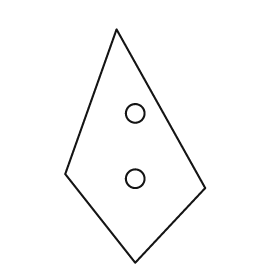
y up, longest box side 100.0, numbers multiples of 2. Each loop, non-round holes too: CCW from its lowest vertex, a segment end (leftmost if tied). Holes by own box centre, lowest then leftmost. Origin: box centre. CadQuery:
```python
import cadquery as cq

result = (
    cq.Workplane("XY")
    .moveTo(0.0, -50.0)
    .lineTo(30.0, -18.0)
    .lineTo(-8.0, 50.0)
    .lineTo(-30.0, -12.0)
    .close()
    .moveTo(0.0, -14.0)
    .circle(4.0)
    .moveTo(0.0, 14.0)
    .circle(4.0)
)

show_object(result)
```